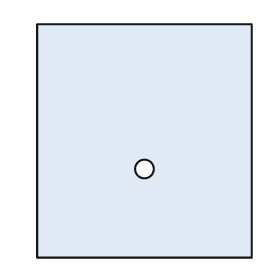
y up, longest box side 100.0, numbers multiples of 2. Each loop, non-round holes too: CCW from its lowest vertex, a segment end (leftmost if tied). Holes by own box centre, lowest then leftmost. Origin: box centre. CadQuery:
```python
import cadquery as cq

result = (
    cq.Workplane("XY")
    .moveTo(-46.0, -50.0)
    .lineTo(46.0, -50.0)
    .lineTo(46.0, 50.0)
    .lineTo(-46.0, 50.0)
    .close()
    .moveTo(0.0, -12.0)
    .circle(4.0)
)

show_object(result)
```